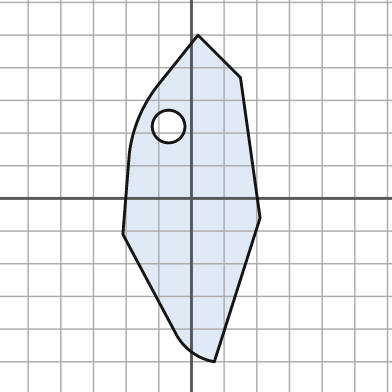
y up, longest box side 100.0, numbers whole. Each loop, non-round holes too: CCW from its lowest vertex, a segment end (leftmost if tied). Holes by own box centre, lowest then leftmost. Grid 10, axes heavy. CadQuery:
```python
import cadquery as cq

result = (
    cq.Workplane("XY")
    .moveTo(7.0, -50.0)
    .lineTo(21.0, -6.0)
    .lineTo(15.0, 37.0)
    .lineTo(2.0, 50.0)
    .lineTo(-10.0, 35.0)
    .threePointArc((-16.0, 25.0), (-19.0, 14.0))
    .lineTo(-21.0, -11.0)
    .lineTo(-5.0, -41.0)
    .threePointArc((0.0, -47.0), (7.0, -50.0))
    .close()
    .moveTo(-7.0, 22.0)
    .circle(5.0)
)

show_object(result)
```